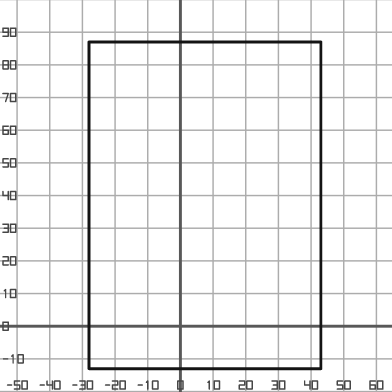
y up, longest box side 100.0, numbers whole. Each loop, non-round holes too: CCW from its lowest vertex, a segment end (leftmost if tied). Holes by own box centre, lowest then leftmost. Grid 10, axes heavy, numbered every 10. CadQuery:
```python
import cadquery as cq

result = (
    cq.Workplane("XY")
    .moveTo(-28.0, -13.0)
    .lineTo(43.0, -13.0)
    .lineTo(43.0, 87.0)
    .lineTo(-28.0, 87.0)
    .close()
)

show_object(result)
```